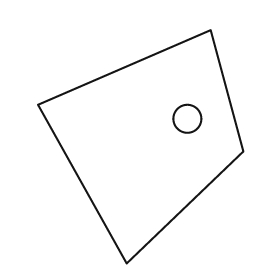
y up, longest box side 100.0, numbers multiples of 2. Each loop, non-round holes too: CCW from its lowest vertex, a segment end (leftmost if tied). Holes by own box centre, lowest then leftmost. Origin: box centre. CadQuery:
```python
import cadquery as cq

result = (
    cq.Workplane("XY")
    .moveTo(-6.0, -50.0)
    .lineTo(44.0, -2.0)
    .lineTo(30.0, 50.0)
    .lineTo(-44.0, 18.0)
    .close()
    .moveTo(20.0, 12.0)
    .circle(6.0)
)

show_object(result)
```